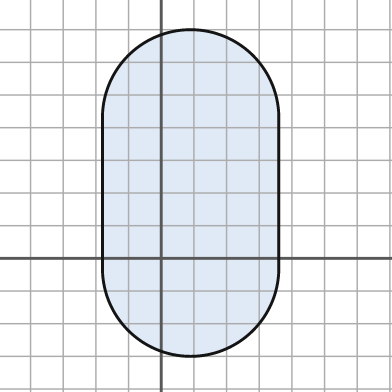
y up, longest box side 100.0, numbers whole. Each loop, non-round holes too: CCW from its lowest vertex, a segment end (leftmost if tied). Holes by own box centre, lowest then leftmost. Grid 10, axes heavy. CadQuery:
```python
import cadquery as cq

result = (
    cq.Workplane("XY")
    .moveTo(-18.0, -3.0)
    .threePointArc((9.0, -30.0), (36.0, -3.0))
    .lineTo(36.0, 43.0)
    .threePointArc((9.0, 70.0), (-18.0, 43.0))
    .close()
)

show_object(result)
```